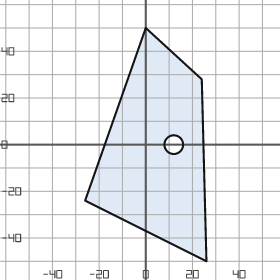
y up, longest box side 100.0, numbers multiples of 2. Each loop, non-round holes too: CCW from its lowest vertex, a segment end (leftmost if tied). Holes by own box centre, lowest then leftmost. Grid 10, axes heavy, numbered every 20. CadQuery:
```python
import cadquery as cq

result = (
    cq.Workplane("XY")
    .moveTo(26.0, -50.0)
    .lineTo(24.0, 28.0)
    .lineTo(0.0, 50.0)
    .lineTo(-26.0, -24.0)
    .close()
    .moveTo(12.0, 0.0)
    .circle(4.0)
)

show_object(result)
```